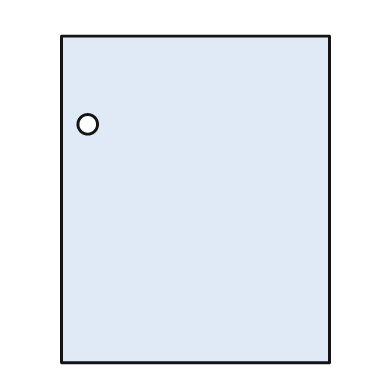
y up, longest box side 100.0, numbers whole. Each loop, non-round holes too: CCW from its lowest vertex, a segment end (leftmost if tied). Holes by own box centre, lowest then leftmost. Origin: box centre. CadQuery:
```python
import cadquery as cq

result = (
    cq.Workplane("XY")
    .moveTo(-41.0, -50.0)
    .lineTo(41.0, -50.0)
    .lineTo(41.0, 50.0)
    .lineTo(-41.0, 50.0)
    .close()
    .moveTo(-33.0, 23.0)
    .circle(3.0)
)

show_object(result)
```